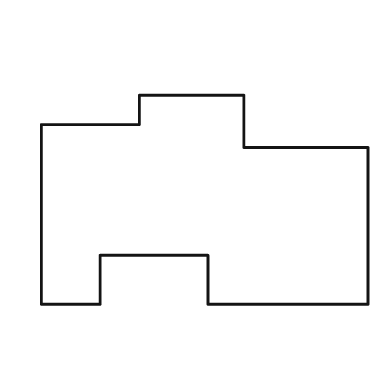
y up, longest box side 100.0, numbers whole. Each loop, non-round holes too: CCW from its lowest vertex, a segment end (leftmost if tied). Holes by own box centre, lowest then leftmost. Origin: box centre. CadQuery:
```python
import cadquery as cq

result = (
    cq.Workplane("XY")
    .moveTo(-50.0, -32.0)
    .lineTo(-32.0, -32.0)
    .lineTo(-32.0, -17.0)
    .lineTo(1.0, -17.0)
    .lineTo(1.0, -32.0)
    .lineTo(50.0, -32.0)
    .lineTo(50.0, 16.0)
    .lineTo(12.0, 16.0)
    .lineTo(12.0, 32.0)
    .lineTo(-20.0, 32.0)
    .lineTo(-20.0, 23.0)
    .lineTo(-50.0, 23.0)
    .close()
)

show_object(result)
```